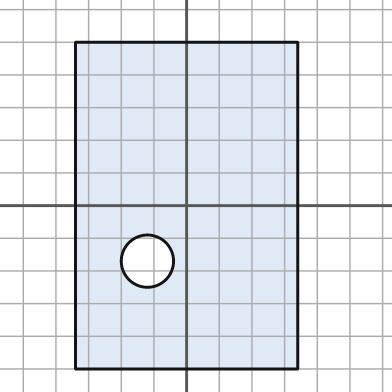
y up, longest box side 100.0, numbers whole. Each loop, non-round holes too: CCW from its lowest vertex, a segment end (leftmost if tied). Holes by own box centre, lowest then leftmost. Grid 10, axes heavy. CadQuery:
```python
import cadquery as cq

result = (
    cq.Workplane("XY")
    .moveTo(-34.0, -50.0)
    .lineTo(34.0, -50.0)
    .lineTo(34.0, 50.0)
    .lineTo(-34.0, 50.0)
    .close()
    .moveTo(-12.0, -17.0)
    .circle(8.0)
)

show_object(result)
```